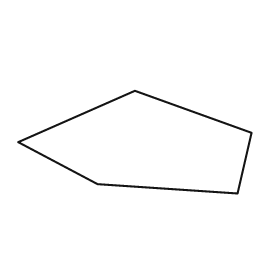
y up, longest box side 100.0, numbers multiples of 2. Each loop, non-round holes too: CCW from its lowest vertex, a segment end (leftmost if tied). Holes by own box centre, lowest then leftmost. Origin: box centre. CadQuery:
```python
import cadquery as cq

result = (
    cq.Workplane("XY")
    .moveTo(44.0, -22.0)
    .lineTo(50.0, 4.0)
    .lineTo(0.0, 22.0)
    .lineTo(-50.0, 0.0)
    .lineTo(-16.0, -18.0)
    .close()
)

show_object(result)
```